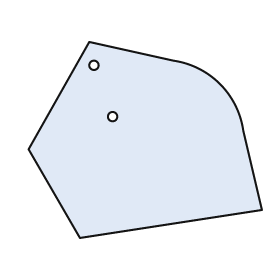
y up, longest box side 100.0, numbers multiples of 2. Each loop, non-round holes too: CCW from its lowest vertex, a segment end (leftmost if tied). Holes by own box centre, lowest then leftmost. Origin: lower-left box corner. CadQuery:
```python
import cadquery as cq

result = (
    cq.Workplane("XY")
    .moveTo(22.0, 0.0)
    .lineTo(100.0, 12.0)
    .lineTo(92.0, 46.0)
    .threePointArc((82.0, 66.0), (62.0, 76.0))
    .lineTo(26.0, 84.0)
    .lineTo(0.0, 38.0)
    .close()
    .moveTo(36.0, 52.0)
    .circle(2.0)
    .moveTo(28.0, 74.0)
    .circle(2.0)
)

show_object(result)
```